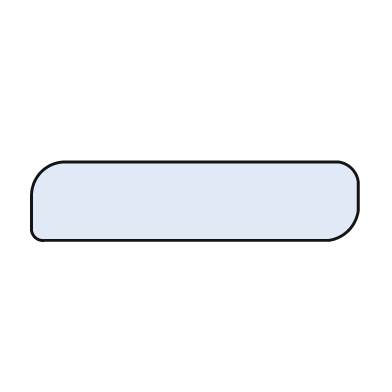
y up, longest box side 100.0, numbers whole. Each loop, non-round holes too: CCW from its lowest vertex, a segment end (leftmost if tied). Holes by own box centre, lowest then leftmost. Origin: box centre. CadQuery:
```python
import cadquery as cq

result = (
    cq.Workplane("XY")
    .moveTo(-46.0, -12.0)
    .lineTo(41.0, -12.0)
    .threePointArc((47.0, -9.0), (50.0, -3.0))
    .lineTo(50.0, 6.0)
    .threePointArc((48.0, 10.0), (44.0, 12.0))
    .lineTo(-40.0, 12.0)
    .threePointArc((-47.0, 9.0), (-50.0, 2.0))
    .lineTo(-50.0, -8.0)
    .threePointArc((-49.0, -11.0), (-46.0, -12.0))
    .close()
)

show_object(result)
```